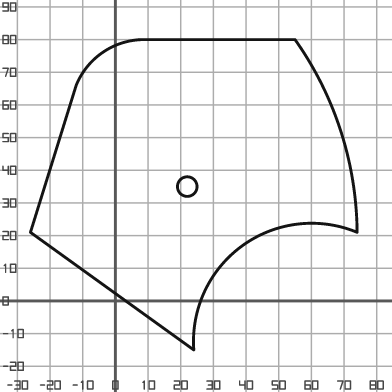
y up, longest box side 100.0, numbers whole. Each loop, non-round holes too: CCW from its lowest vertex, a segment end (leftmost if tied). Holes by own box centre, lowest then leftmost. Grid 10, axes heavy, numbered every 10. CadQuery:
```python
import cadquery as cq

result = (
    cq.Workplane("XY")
    .moveTo(24.0, -15.0)
    .threePointArc((39.0, 17.0), (74.0, 21.0))
    .threePointArc((69.0, 52.0), (55.0, 80.0))
    .lineTo(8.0, 80.0)
    .threePointArc((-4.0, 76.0), (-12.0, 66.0))
    .lineTo(-26.0, 21.0)
    .close()
    .moveTo(22.0, 35.0)
    .circle(3.0)
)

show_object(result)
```